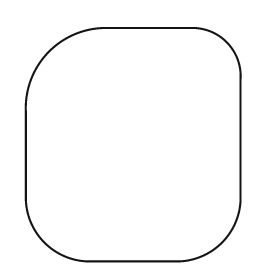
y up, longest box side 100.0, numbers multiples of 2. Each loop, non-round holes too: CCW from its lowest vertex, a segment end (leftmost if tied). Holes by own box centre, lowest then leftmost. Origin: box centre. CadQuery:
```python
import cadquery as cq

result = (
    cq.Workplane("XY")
    .moveTo(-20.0, -50.0)
    .lineTo(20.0, -50.0)
    .threePointArc((38.0, -42.0), (46.0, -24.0))
    .lineTo(46.0, 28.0)
    .threePointArc((40.0, 44.0), (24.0, 50.0))
    .lineTo(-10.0, 50.0)
    .threePointArc((-36.0, 40.0), (-46.0, 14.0))
    .lineTo(-46.0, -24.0)
    .threePointArc((-38.0, -42.0), (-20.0, -50.0))
    .close()
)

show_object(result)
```